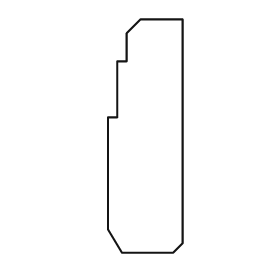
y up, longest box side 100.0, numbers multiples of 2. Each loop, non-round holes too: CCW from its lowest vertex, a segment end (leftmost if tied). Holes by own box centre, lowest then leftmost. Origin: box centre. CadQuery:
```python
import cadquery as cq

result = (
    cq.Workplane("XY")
    .moveTo(-10.0, -50.0)
    .lineTo(12.0, -50.0)
    .lineTo(16.0, -46.0)
    .lineTo(16.0, 50.0)
    .lineTo(-2.0, 50.0)
    .lineTo(-8.0, 44.0)
    .lineTo(-8.0, 32.0)
    .lineTo(-12.0, 32.0)
    .lineTo(-12.0, 8.0)
    .lineTo(-16.0, 8.0)
    .lineTo(-16.0, -40.0)
    .close()
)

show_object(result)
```